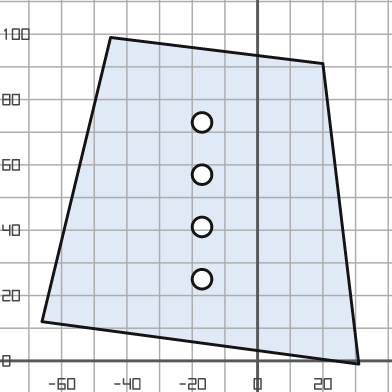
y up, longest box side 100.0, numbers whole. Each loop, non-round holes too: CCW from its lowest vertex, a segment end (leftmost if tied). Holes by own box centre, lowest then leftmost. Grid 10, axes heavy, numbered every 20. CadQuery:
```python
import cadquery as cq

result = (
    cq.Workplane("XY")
    .moveTo(31.0, -1.0)
    .lineTo(20.0, 91.0)
    .lineTo(-45.0, 99.0)
    .lineTo(-66.0, 12.0)
    .close()
    .moveTo(-17.0, 25.0)
    .circle(3.0)
    .moveTo(-17.0, 41.0)
    .circle(3.0)
    .moveTo(-17.0, 57.0)
    .circle(3.0)
    .moveTo(-17.0, 73.0)
    .circle(3.0)
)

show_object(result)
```